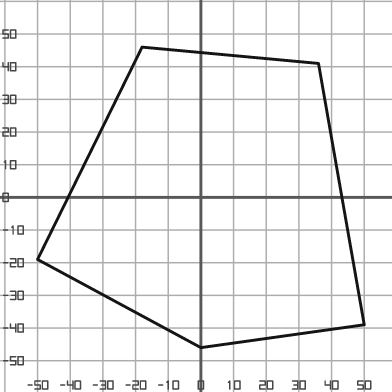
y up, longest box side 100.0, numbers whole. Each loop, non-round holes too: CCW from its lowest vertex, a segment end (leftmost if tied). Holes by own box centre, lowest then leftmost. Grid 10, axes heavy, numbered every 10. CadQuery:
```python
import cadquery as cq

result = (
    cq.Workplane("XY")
    .moveTo(0.0, -46.0)
    .lineTo(50.0, -39.0)
    .lineTo(36.0, 41.0)
    .lineTo(-18.0, 46.0)
    .lineTo(-50.0, -19.0)
    .close()
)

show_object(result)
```